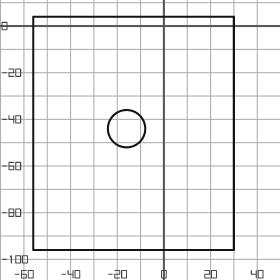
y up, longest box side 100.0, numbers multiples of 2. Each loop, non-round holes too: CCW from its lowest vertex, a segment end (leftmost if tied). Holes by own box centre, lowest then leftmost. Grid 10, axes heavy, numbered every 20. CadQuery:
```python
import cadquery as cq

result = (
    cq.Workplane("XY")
    .moveTo(-56.0, -96.0)
    .lineTo(30.0, -96.0)
    .lineTo(30.0, 4.0)
    .lineTo(-56.0, 4.0)
    .close()
    .moveTo(-16.0, -44.0)
    .circle(8.0)
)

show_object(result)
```